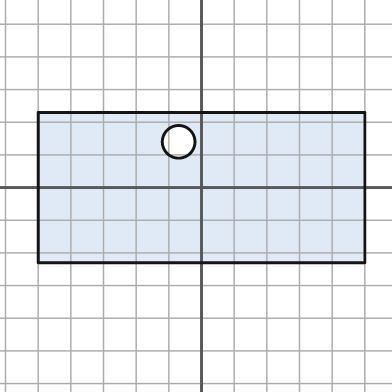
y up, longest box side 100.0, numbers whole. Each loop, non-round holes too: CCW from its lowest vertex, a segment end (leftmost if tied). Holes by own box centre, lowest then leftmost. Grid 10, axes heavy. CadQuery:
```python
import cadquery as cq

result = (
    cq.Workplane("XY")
    .moveTo(-50.0, -23.0)
    .lineTo(50.0, -23.0)
    .lineTo(50.0, 23.0)
    .lineTo(-50.0, 23.0)
    .close()
    .moveTo(-7.0, 14.0)
    .circle(5.0)
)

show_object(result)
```